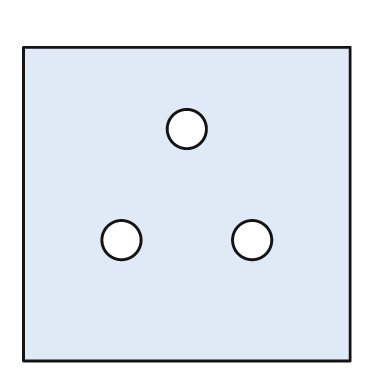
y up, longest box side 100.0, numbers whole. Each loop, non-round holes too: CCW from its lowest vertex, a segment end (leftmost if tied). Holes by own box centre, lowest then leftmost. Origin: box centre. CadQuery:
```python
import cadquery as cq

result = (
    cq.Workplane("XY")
    .moveTo(-50.0, -48.0)
    .lineTo(50.0, -48.0)
    .lineTo(50.0, 48.0)
    .lineTo(-50.0, 48.0)
    .close()
    .moveTo(-20.0, -11.0)
    .circle(6.0)
    .moveTo(20.0, -11.0)
    .circle(6.0)
    .moveTo(0.0, 23.0)
    .circle(6.0)
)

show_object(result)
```